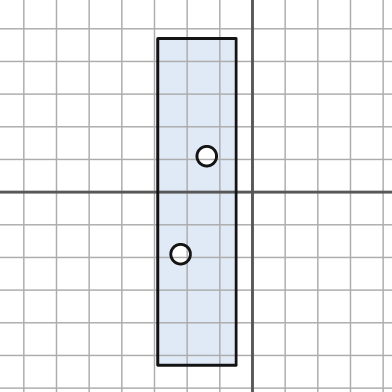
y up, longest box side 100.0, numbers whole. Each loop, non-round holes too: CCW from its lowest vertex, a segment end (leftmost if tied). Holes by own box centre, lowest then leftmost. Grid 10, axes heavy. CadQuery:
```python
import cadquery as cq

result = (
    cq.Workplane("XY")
    .moveTo(-29.0, -53.0)
    .lineTo(-5.0, -53.0)
    .lineTo(-5.0, 47.0)
    .lineTo(-29.0, 47.0)
    .close()
    .moveTo(-22.0, -19.0)
    .circle(3.0)
    .moveTo(-14.0, 11.0)
    .circle(3.0)
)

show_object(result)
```